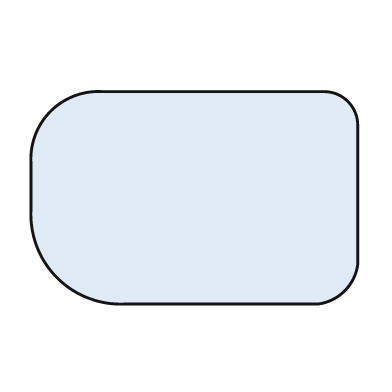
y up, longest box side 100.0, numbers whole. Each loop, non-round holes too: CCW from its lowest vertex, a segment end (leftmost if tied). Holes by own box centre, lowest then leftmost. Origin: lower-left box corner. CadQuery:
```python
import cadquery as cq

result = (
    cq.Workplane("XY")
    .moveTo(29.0, 0.0)
    .lineTo(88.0, 0.0)
    .threePointArc((96.0, 4.0), (100.0, 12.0))
    .lineTo(100.0, 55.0)
    .threePointArc((97.0, 62.0), (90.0, 65.0))
    .lineTo(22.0, 65.0)
    .threePointArc((6.0, 59.0), (0.0, 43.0))
    .lineTo(0.0, 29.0)
    .threePointArc((8.0, 8.0), (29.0, 0.0))
    .close()
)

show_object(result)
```